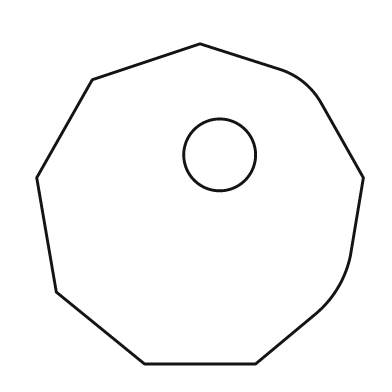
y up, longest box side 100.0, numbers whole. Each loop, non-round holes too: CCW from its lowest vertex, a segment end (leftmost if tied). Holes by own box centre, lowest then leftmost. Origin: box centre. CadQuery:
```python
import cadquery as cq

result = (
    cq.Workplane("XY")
    .moveTo(-17.0, -49.0)
    .lineTo(17.0, -49.0)
    .lineTo(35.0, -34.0)
    .threePointArc((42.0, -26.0), (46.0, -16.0))
    .lineTo(50.0, 8.0)
    .lineTo(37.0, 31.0)
    .threePointArc((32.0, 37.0), (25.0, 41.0))
    .lineTo(0.0, 49.0)
    .lineTo(-33.0, 38.0)
    .lineTo(-50.0, 8.0)
    .lineTo(-44.0, -27.0)
    .close()
    .moveTo(6.0, 15.0)
    .circle(11.0)
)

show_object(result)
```